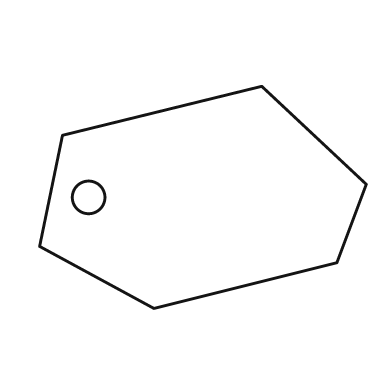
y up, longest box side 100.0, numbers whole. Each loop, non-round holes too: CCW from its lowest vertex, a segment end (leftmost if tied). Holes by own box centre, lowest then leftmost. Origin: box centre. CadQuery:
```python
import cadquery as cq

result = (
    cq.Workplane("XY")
    .moveTo(-15.0, -34.0)
    .lineTo(41.0, -20.0)
    .lineTo(50.0, 4.0)
    .lineTo(18.0, 34.0)
    .lineTo(-43.0, 19.0)
    .lineTo(-50.0, -15.0)
    .close()
    .moveTo(-35.0, 0.0)
    .circle(5.0)
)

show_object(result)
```